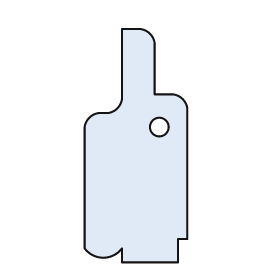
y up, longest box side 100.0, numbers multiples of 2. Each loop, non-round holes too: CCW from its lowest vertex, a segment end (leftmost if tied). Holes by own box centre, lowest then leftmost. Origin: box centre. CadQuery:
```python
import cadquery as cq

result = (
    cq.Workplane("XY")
    .moveTo(-6.0, -50.0)
    .lineTo(18.0, -50.0)
    .lineTo(18.0, -40.0)
    .lineTo(22.0, -40.0)
    .lineTo(22.0, 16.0)
    .threePointArc((20.0, 20.0), (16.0, 22.0))
    .lineTo(8.0, 22.0)
    .lineTo(8.0, 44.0)
    .threePointArc((6.0, 48.0), (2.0, 50.0))
    .lineTo(-6.0, 50.0)
    .lineTo(-6.0, 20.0)
    .threePointArc((-8.0, 16.0), (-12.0, 14.0))
    .lineTo(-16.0, 14.0)
    .threePointArc((-20.0, 12.0), (-22.0, 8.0))
    .lineTo(-22.0, -44.0)
    .threePointArc((-14.0, -48.0), (-6.0, -44.0))
    .close()
    .moveTo(10.0, 8.0)
    .circle(4.0)
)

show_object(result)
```